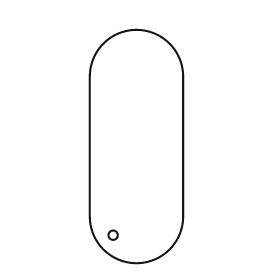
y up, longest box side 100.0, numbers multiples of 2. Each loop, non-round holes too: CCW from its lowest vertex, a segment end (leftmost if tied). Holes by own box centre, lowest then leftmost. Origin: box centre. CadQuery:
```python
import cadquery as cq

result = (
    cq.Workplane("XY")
    .moveTo(-20.0, -30.0)
    .threePointArc((0.0, -50.0), (20.0, -30.0))
    .lineTo(20.0, 30.0)
    .threePointArc((0.0, 50.0), (-20.0, 30.0))
    .close()
    .moveTo(-10.0, -38.0)
    .circle(2.0)
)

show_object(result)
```